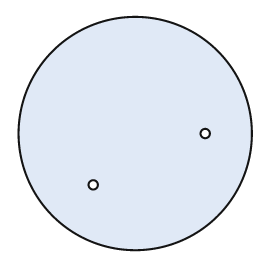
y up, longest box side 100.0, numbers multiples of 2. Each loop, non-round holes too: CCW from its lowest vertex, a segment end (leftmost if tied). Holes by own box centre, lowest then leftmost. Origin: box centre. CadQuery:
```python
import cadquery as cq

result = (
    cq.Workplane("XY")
    .moveTo(0.0, 0.0)
    .circle(50.0)
    .moveTo(-18.0, -22.0)
    .circle(2.0)
    .moveTo(30.0, 0.0)
    .circle(2.0)
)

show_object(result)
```